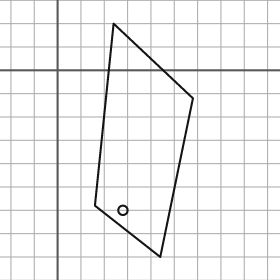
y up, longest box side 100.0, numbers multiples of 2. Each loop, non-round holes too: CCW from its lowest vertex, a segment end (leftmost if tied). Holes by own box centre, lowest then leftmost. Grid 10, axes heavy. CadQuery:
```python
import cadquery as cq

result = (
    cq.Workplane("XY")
    .moveTo(44.0, -80.0)
    .lineTo(58.0, -12.0)
    .lineTo(24.0, 20.0)
    .lineTo(16.0, -58.0)
    .close()
    .moveTo(28.0, -60.0)
    .circle(2.0)
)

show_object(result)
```